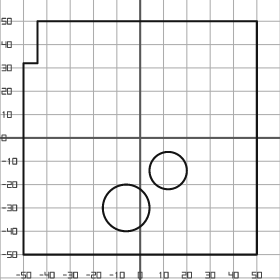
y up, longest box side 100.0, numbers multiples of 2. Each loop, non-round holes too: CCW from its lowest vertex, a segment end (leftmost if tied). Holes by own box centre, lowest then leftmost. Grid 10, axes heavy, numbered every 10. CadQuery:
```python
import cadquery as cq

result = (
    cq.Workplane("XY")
    .moveTo(-50.0, -50.0)
    .lineTo(50.0, -50.0)
    .lineTo(50.0, 50.0)
    .lineTo(-44.0, 50.0)
    .lineTo(-44.0, 32.0)
    .lineTo(-50.0, 32.0)
    .close()
    .moveTo(-6.0, -30.0)
    .circle(10.0)
    .moveTo(12.0, -14.0)
    .circle(8.0)
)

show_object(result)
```